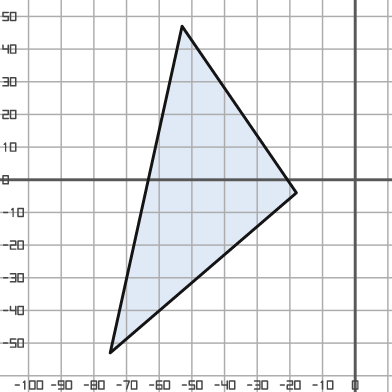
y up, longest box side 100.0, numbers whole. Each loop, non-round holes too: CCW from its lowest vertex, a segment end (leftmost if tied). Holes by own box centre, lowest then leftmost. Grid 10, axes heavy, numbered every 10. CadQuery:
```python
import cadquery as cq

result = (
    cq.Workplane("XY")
    .moveTo(-75.0, -53.0)
    .lineTo(-18.0, -4.0)
    .lineTo(-53.0, 47.0)
    .close()
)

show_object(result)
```